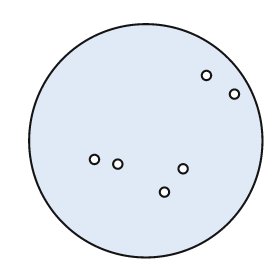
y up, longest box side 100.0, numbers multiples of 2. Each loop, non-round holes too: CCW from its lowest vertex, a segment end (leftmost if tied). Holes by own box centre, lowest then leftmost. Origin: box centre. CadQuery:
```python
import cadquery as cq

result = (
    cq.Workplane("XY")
    .moveTo(0.0, 0.0)
    .circle(50.0)
    .moveTo(8.0, -22.0)
    .circle(2.0)
    .moveTo(16.0, -12.0)
    .circle(2.0)
    .moveTo(-12.0, -10.0)
    .circle(2.0)
    .moveTo(-22.0, -8.0)
    .circle(2.0)
    .moveTo(38.0, 20.0)
    .circle(2.0)
    .moveTo(26.0, 28.0)
    .circle(2.0)
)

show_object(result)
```